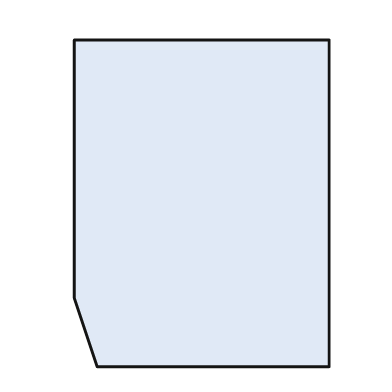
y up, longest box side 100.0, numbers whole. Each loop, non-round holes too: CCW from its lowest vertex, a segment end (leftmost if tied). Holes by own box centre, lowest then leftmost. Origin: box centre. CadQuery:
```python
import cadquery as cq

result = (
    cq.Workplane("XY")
    .moveTo(-32.0, -50.0)
    .lineTo(39.0, -50.0)
    .lineTo(39.0, 50.0)
    .lineTo(-39.0, 50.0)
    .lineTo(-39.0, -29.0)
    .close()
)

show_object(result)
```